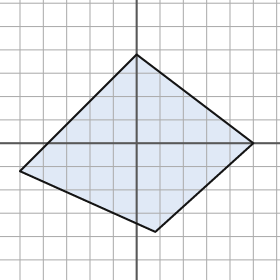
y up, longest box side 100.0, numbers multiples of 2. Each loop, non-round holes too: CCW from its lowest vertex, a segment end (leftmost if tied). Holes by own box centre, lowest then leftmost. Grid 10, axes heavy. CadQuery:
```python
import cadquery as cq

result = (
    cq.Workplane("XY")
    .moveTo(8.0, -38.0)
    .lineTo(50.0, 0.0)
    .lineTo(0.0, 38.0)
    .lineTo(-50.0, -12.0)
    .close()
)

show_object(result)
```